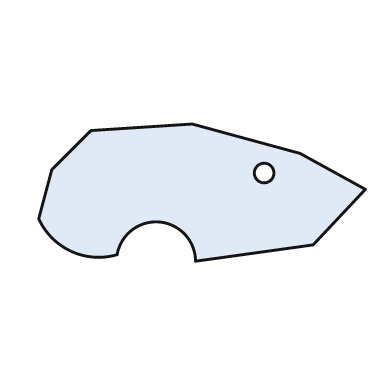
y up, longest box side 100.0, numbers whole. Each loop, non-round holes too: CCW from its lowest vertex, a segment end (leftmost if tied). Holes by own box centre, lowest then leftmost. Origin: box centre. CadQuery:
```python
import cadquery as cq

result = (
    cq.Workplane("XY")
    .moveTo(-2.0, -21.0)
    .lineTo(34.0, -16.0)
    .lineTo(50.0, 1.0)
    .lineTo(30.0, 12.0)
    .lineTo(-3.0, 21.0)
    .lineTo(-34.0, 19.0)
    .lineTo(-46.0, 7.0)
    .lineTo(-50.0, -8.0)
    .threePointArc((-40.0, -18.0), (-26.0, -19.0))
    .threePointArc((-13.0, -9.0), (-2.0, -21.0))
    .close()
    .moveTo(19.0, 6.0)
    .circle(3.0)
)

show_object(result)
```